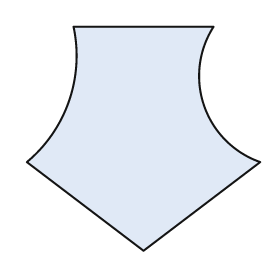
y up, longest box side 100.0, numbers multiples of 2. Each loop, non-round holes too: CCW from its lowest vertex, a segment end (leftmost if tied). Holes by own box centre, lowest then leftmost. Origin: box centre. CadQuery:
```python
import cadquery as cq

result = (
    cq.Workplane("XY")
    .moveTo(0.0, -48.0)
    .lineTo(50.0, -10.0)
    .threePointArc((26.0, 14.0), (30.0, 48.0))
    .lineTo(-30.0, 48.0)
    .threePointArc((-32.0, 16.0), (-50.0, -10.0))
    .close()
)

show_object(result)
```